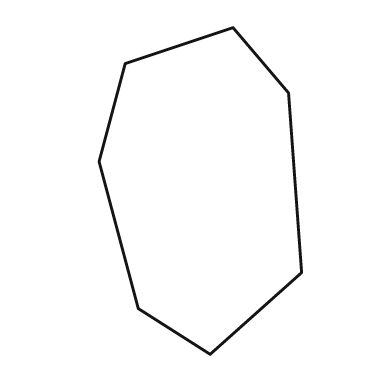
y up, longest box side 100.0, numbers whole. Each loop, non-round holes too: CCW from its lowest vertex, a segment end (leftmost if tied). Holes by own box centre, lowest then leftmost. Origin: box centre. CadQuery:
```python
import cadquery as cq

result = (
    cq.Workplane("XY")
    .moveTo(3.0, -50.0)
    .lineTo(31.0, -25.0)
    .lineTo(27.0, 30.0)
    .lineTo(10.0, 50.0)
    .lineTo(-23.0, 39.0)
    .lineTo(-31.0, 9.0)
    .lineTo(-19.0, -36.0)
    .close()
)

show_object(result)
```